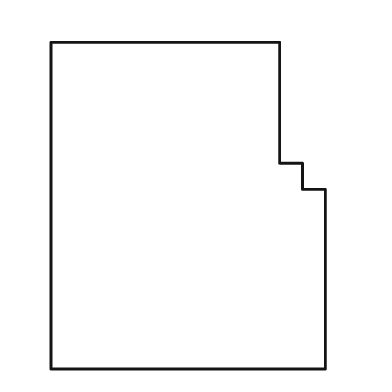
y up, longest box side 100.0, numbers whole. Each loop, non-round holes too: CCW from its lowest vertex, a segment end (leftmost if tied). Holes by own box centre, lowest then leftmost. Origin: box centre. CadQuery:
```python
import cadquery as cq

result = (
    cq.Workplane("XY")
    .moveTo(-42.0, -50.0)
    .lineTo(42.0, -50.0)
    .lineTo(42.0, 5.0)
    .lineTo(35.0, 5.0)
    .lineTo(35.0, 13.0)
    .lineTo(28.0, 13.0)
    .lineTo(28.0, 50.0)
    .lineTo(-42.0, 50.0)
    .close()
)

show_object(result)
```